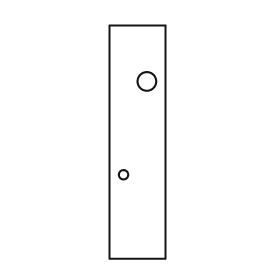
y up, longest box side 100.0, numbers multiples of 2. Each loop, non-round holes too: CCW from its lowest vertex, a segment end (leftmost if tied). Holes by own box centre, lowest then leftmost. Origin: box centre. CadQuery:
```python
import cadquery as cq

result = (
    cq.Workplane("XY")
    .moveTo(-12.0, -50.0)
    .lineTo(12.0, -50.0)
    .lineTo(12.0, 50.0)
    .lineTo(-12.0, 50.0)
    .close()
    .moveTo(-6.0, -14.0)
    .circle(2.0)
    .moveTo(4.0, 26.0)
    .circle(4.0)
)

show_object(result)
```